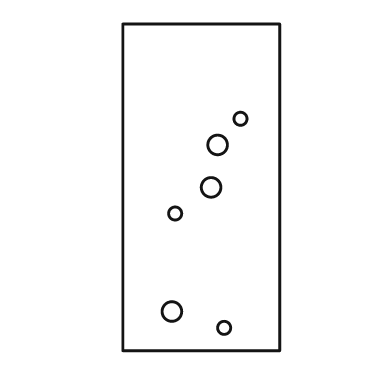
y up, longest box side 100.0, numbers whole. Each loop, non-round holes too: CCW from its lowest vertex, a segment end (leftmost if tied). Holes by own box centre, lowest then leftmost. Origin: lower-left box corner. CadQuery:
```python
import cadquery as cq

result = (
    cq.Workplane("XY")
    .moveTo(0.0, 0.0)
    .lineTo(48.0, 0.0)
    .lineTo(48.0, 100.0)
    .lineTo(0.0, 100.0)
    .close()
    .moveTo(31.0, 7.0)
    .circle(2.0)
    .moveTo(15.0, 12.0)
    .circle(3.0)
    .moveTo(16.0, 42.0)
    .circle(2.0)
    .moveTo(27.0, 50.0)
    .circle(3.0)
    .moveTo(29.0, 63.0)
    .circle(3.0)
    .moveTo(36.0, 71.0)
    .circle(2.0)
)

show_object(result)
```